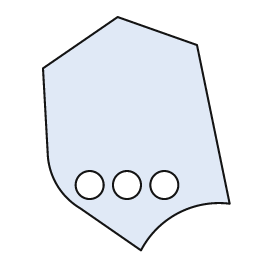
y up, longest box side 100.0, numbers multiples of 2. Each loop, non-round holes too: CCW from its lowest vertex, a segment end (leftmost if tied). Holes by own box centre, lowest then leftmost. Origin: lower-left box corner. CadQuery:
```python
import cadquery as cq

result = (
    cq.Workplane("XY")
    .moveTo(42.0, 0.0)
    .threePointArc((58.0, 16.0), (80.0, 20.0))
    .lineTo(66.0, 88.0)
    .lineTo(32.0, 100.0)
    .lineTo(0.0, 78.0)
    .lineTo(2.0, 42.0)
    .threePointArc((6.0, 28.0), (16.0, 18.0))
    .close()
    .moveTo(20.0, 28.0)
    .circle(6.0)
    .moveTo(36.0, 28.0)
    .circle(6.0)
    .moveTo(52.0, 28.0)
    .circle(6.0)
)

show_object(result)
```